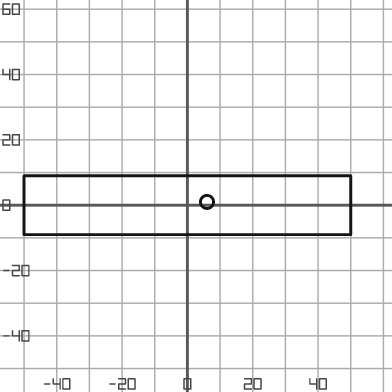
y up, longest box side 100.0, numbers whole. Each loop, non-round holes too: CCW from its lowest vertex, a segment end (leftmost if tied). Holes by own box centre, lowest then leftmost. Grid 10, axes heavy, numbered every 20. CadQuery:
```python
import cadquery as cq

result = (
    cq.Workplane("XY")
    .moveTo(-50.0, -9.0)
    .lineTo(50.0, -9.0)
    .lineTo(50.0, 9.0)
    .lineTo(-50.0, 9.0)
    .close()
    .moveTo(6.0, 1.0)
    .circle(2.0)
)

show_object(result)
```